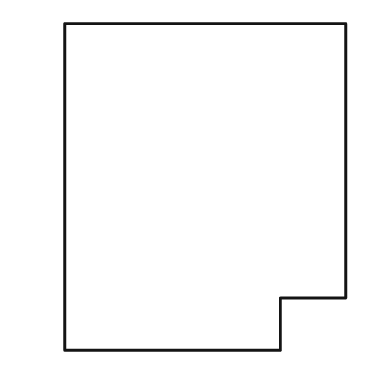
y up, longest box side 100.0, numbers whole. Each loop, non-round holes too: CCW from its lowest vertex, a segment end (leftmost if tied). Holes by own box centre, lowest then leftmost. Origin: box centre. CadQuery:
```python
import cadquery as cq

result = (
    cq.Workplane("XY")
    .moveTo(-43.0, -50.0)
    .lineTo(23.0, -50.0)
    .lineTo(23.0, -34.0)
    .lineTo(43.0, -34.0)
    .lineTo(43.0, 50.0)
    .lineTo(-43.0, 50.0)
    .close()
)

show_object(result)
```